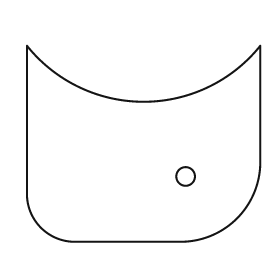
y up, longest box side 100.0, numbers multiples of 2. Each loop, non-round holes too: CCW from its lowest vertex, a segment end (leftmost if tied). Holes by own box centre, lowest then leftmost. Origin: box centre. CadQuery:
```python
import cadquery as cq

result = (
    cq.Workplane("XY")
    .moveTo(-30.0, -42.0)
    .lineTo(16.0, -42.0)
    .threePointArc((40.0, -32.0), (50.0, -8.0))
    .lineTo(50.0, 42.0)
    .threePointArc((0.0, 18.0), (-50.0, 42.0))
    .lineTo(-50.0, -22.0)
    .threePointArc((-44.0, -36.0), (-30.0, -42.0))
    .close()
    .moveTo(18.0, -14.0)
    .circle(4.0)
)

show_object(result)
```